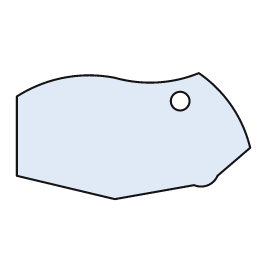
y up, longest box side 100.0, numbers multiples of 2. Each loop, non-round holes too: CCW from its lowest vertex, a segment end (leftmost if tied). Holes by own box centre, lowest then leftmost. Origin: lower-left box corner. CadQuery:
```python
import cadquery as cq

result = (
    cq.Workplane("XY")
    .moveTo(42.0, 0.0)
    .lineTo(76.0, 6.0)
    .threePointArc((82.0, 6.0), (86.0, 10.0))
    .lineTo(100.0, 22.0)
    .threePointArc((92.0, 40.0), (78.0, 54.0))
    .threePointArc((60.0, 50.0), (42.0, 52.0))
    .threePointArc((20.0, 52.0), (0.0, 44.0))
    .lineTo(0.0, 10.0)
    .close()
    .moveTo(70.0, 42.0)
    .circle(4.0)
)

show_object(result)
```